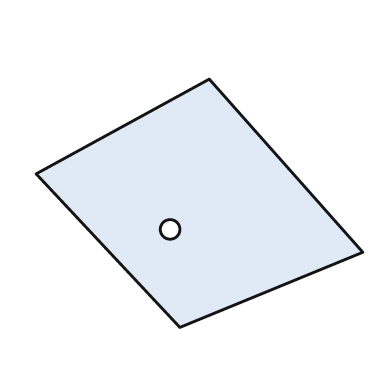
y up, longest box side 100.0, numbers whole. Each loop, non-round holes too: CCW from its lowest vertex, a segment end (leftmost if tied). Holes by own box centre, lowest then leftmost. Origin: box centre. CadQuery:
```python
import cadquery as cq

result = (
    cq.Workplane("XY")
    .moveTo(-6.0, -38.0)
    .lineTo(50.0, -15.0)
    .lineTo(3.0, 38.0)
    .lineTo(-50.0, 9.0)
    .close()
    .moveTo(-9.0, -8.0)
    .circle(3.0)
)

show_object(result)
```